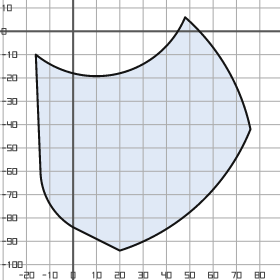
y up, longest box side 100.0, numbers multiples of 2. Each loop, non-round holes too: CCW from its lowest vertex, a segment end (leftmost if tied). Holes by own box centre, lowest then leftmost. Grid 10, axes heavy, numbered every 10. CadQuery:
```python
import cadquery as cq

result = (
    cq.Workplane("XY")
    .moveTo(20.0, -94.0)
    .threePointArc((54.0, -74.0), (76.0, -42.0))
    .threePointArc((66.0, -16.0), (48.0, 6.0))
    .threePointArc((20.0, -18.0), (-16.0, -10.0))
    .lineTo(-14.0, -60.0)
    .threePointArc((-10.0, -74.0), (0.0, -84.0))
    .close()
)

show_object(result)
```